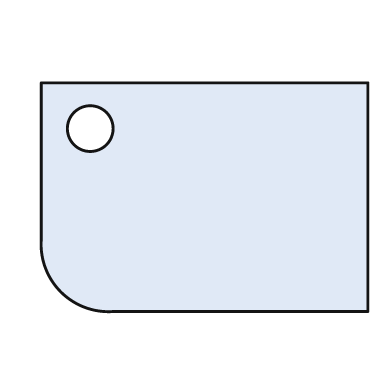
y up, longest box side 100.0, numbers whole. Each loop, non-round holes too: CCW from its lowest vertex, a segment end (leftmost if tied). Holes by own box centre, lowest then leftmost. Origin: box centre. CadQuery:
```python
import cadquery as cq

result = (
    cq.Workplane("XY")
    .moveTo(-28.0, -35.0)
    .lineTo(50.0, -35.0)
    .lineTo(50.0, 35.0)
    .lineTo(-50.0, 35.0)
    .lineTo(-50.0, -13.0)
    .threePointArc((-44.0, -29.0), (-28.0, -35.0))
    .close()
    .moveTo(-35.0, 21.0)
    .circle(7.0)
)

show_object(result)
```